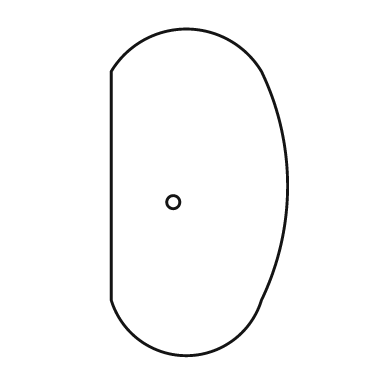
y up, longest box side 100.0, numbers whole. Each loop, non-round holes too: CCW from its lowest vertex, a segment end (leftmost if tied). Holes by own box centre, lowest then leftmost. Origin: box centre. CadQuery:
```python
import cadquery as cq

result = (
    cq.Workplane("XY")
    .moveTo(-27.0, -33.0)
    .threePointArc((-4.0, -50.0), (19.0, -33.0))
    .threePointArc((27.0, 2.0), (19.0, 37.0))
    .threePointArc((-4.0, 50.0), (-27.0, 37.0))
    .close()
    .moveTo(-8.0, -3.0)
    .circle(2.0)
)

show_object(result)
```